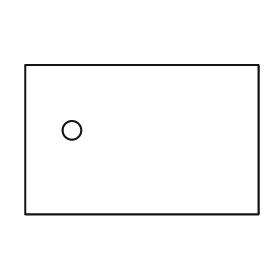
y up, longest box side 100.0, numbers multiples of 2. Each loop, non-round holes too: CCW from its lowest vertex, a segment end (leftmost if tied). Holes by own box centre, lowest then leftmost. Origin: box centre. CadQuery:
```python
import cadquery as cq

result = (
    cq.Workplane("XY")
    .moveTo(-50.0, -32.0)
    .lineTo(50.0, -32.0)
    .lineTo(50.0, 32.0)
    .lineTo(-50.0, 32.0)
    .close()
    .moveTo(-30.0, 4.0)
    .circle(4.0)
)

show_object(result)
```